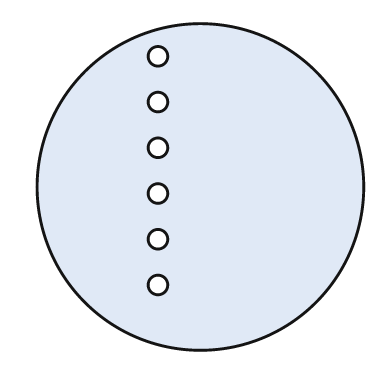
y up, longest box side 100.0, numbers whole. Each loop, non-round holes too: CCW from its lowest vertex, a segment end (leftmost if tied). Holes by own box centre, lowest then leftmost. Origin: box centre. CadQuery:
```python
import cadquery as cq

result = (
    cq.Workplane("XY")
    .moveTo(0.0, 0.0)
    .circle(50.0)
    .moveTo(-13.0, -30.0)
    .circle(3.0)
    .moveTo(-13.0, -16.0)
    .circle(3.0)
    .moveTo(-13.0, -2.0)
    .circle(3.0)
    .moveTo(-13.0, 12.0)
    .circle(3.0)
    .moveTo(-13.0, 26.0)
    .circle(3.0)
    .moveTo(-13.0, 40.0)
    .circle(3.0)
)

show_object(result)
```